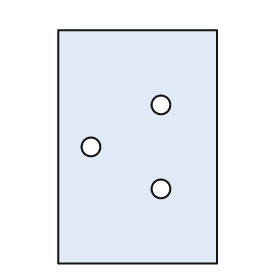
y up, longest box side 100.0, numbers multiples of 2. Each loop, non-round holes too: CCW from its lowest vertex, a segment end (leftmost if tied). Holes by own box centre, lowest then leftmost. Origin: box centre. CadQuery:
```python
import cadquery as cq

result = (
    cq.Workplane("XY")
    .moveTo(-34.0, -50.0)
    .lineTo(34.0, -50.0)
    .lineTo(34.0, 50.0)
    .lineTo(-34.0, 50.0)
    .close()
    .moveTo(10.0, -18.0)
    .circle(4.0)
    .moveTo(-20.0, 0.0)
    .circle(4.0)
    .moveTo(10.0, 18.0)
    .circle(4.0)
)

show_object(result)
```